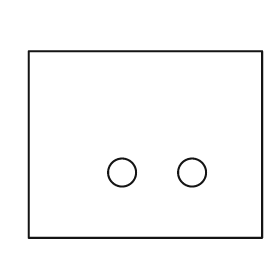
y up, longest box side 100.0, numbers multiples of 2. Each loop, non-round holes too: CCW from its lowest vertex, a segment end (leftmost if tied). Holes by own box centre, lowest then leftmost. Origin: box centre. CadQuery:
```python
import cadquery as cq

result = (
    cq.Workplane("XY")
    .moveTo(-50.0, -40.0)
    .lineTo(50.0, -40.0)
    .lineTo(50.0, 40.0)
    .lineTo(-50.0, 40.0)
    .close()
    .moveTo(-10.0, -12.0)
    .circle(6.0)
    .moveTo(20.0, -12.0)
    .circle(6.0)
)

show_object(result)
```